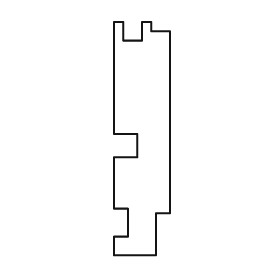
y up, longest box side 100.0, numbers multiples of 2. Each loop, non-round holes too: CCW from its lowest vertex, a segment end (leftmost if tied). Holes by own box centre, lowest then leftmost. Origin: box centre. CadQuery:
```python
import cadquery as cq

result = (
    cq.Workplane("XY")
    .moveTo(-12.0, -50.0)
    .lineTo(6.0, -50.0)
    .lineTo(6.0, -32.0)
    .lineTo(12.0, -32.0)
    .lineTo(12.0, 46.0)
    .lineTo(4.0, 46.0)
    .lineTo(4.0, 50.0)
    .lineTo(0.0, 50.0)
    .lineTo(0.0, 42.0)
    .lineTo(-8.0, 42.0)
    .lineTo(-8.0, 50.0)
    .lineTo(-12.0, 50.0)
    .lineTo(-12.0, 2.0)
    .lineTo(-2.0, 2.0)
    .lineTo(-2.0, -8.0)
    .lineTo(-12.0, -8.0)
    .lineTo(-12.0, -30.0)
    .lineTo(-6.0, -30.0)
    .lineTo(-6.0, -42.0)
    .lineTo(-12.0, -42.0)
    .close()
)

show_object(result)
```